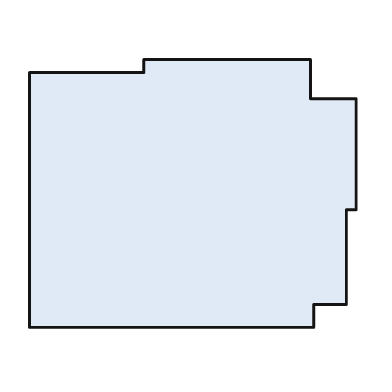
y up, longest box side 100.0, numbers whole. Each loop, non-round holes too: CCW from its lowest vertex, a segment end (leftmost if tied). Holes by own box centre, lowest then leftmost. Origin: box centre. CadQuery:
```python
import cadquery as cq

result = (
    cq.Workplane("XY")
    .moveTo(-50.0, -41.0)
    .lineTo(37.0, -41.0)
    .lineTo(37.0, -34.0)
    .lineTo(47.0, -34.0)
    .lineTo(47.0, -5.0)
    .lineTo(50.0, -5.0)
    .lineTo(50.0, 29.0)
    .lineTo(36.0, 29.0)
    .lineTo(36.0, 41.0)
    .lineTo(-15.0, 41.0)
    .lineTo(-15.0, 37.0)
    .lineTo(-50.0, 37.0)
    .close()
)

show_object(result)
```